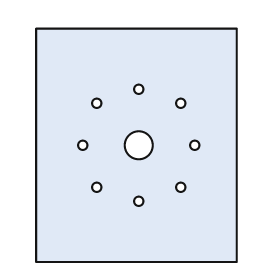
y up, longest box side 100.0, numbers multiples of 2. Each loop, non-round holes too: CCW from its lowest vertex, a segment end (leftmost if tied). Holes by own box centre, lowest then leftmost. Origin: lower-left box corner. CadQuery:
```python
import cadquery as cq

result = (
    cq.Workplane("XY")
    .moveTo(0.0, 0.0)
    .lineTo(86.0, 0.0)
    .lineTo(86.0, 100.0)
    .lineTo(0.0, 100.0)
    .close()
    .moveTo(44.0, 26.0)
    .circle(2.0)
    .moveTo(26.0, 32.0)
    .circle(2.0)
    .moveTo(62.0, 32.0)
    .circle(2.0)
    .moveTo(20.0, 50.0)
    .circle(2.0)
    .moveTo(44.0, 50.0)
    .circle(6.0)
    .moveTo(68.0, 50.0)
    .circle(2.0)
    .moveTo(26.0, 68.0)
    .circle(2.0)
    .moveTo(62.0, 68.0)
    .circle(2.0)
    .moveTo(44.0, 74.0)
    .circle(2.0)
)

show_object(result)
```